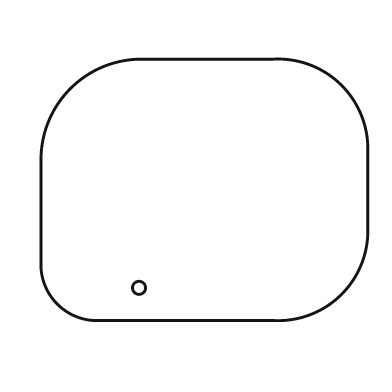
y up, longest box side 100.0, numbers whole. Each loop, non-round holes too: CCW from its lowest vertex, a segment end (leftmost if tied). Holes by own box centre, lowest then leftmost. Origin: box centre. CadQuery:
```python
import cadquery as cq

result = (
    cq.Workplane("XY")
    .moveTo(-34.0, -40.0)
    .lineTo(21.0, -40.0)
    .threePointArc((42.0, -32.0), (50.0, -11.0))
    .lineTo(50.0, 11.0)
    .threePointArc((42.0, 32.0), (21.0, 40.0))
    .lineTo(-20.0, 40.0)
    .threePointArc((-41.0, 31.0), (-50.0, 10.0))
    .lineTo(-50.0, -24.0)
    .threePointArc((-45.0, -35.0), (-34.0, -40.0))
    .close()
    .moveTo(-20.0, -30.0)
    .circle(2.0)
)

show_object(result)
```